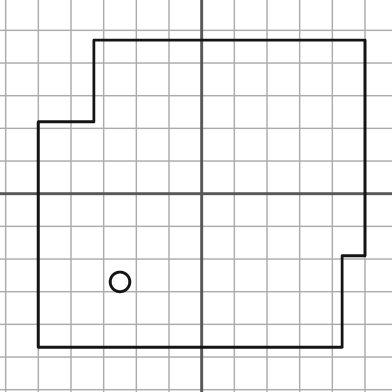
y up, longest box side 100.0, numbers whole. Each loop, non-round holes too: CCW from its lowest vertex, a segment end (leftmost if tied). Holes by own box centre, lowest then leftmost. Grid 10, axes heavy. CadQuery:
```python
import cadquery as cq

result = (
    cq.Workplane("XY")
    .moveTo(-50.0, -47.0)
    .lineTo(43.0, -47.0)
    .lineTo(43.0, -19.0)
    .lineTo(50.0, -19.0)
    .lineTo(50.0, 47.0)
    .lineTo(-33.0, 47.0)
    .lineTo(-33.0, 22.0)
    .lineTo(-50.0, 22.0)
    .close()
    .moveTo(-25.0, -27.0)
    .circle(3.0)
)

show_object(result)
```